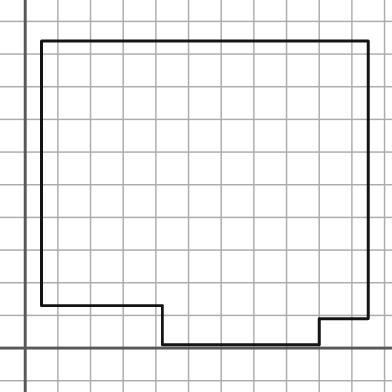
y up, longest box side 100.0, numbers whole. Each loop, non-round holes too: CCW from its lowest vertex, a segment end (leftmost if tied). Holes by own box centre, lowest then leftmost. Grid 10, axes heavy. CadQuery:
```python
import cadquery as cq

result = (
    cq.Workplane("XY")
    .moveTo(42.0, 1.0)
    .lineTo(90.0, 1.0)
    .lineTo(90.0, 9.0)
    .lineTo(105.0, 9.0)
    .lineTo(105.0, 94.0)
    .lineTo(5.0, 94.0)
    .lineTo(5.0, 13.0)
    .lineTo(42.0, 13.0)
    .close()
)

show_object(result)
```